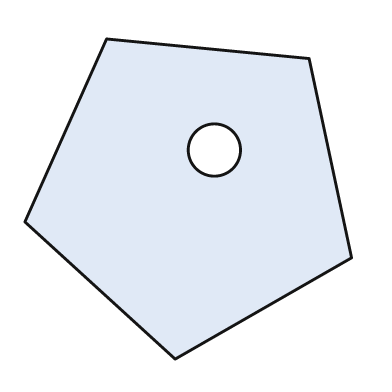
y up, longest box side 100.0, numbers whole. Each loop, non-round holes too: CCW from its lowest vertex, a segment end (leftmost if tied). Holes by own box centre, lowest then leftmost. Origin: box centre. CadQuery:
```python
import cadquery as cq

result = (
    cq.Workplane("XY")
    .moveTo(-4.0, -49.0)
    .lineTo(50.0, -18.0)
    .lineTo(37.0, 43.0)
    .lineTo(-25.0, 49.0)
    .lineTo(-50.0, -7.0)
    .close()
    .moveTo(8.0, 15.0)
    .circle(8.0)
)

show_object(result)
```